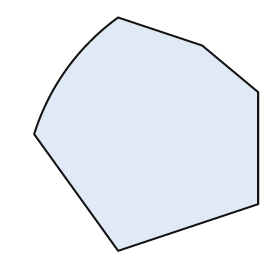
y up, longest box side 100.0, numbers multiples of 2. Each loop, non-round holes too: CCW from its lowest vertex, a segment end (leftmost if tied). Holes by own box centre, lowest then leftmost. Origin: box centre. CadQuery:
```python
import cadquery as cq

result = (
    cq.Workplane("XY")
    .moveTo(-12.0, -50.0)
    .lineTo(48.0, -30.0)
    .lineTo(48.0, 18.0)
    .lineTo(24.0, 38.0)
    .lineTo(-12.0, 50.0)
    .threePointArc((-34.0, 28.0), (-48.0, 0.0))
    .close()
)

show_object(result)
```